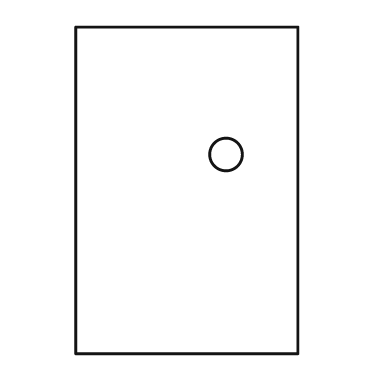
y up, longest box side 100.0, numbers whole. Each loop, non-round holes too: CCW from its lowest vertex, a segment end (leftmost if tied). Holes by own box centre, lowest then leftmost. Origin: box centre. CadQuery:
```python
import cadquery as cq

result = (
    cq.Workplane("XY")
    .moveTo(-34.0, -50.0)
    .lineTo(34.0, -50.0)
    .lineTo(34.0, 50.0)
    .lineTo(-34.0, 50.0)
    .close()
    .moveTo(12.0, 11.0)
    .circle(5.0)
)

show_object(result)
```